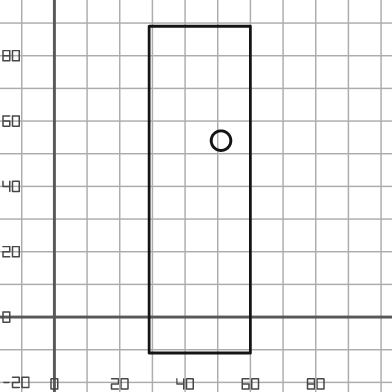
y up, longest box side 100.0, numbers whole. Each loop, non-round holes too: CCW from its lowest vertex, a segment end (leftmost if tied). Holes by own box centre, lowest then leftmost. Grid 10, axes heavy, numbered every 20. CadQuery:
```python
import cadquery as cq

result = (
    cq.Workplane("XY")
    .moveTo(29.0, -11.0)
    .lineTo(60.0, -11.0)
    .lineTo(60.0, 89.0)
    .lineTo(29.0, 89.0)
    .close()
    .moveTo(51.0, 54.0)
    .circle(3.0)
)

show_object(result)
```